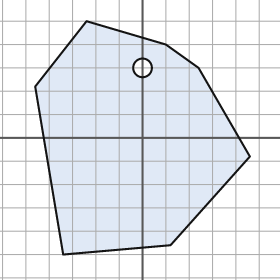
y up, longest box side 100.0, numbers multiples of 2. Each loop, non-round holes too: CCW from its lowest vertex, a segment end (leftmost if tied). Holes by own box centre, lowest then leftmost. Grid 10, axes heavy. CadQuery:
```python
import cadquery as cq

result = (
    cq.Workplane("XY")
    .moveTo(-34.0, -50.0)
    .lineTo(12.0, -46.0)
    .lineTo(46.0, -8.0)
    .lineTo(24.0, 30.0)
    .lineTo(10.0, 40.0)
    .lineTo(-24.0, 50.0)
    .lineTo(-46.0, 22.0)
    .close()
    .moveTo(0.0, 30.0)
    .circle(4.0)
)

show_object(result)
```